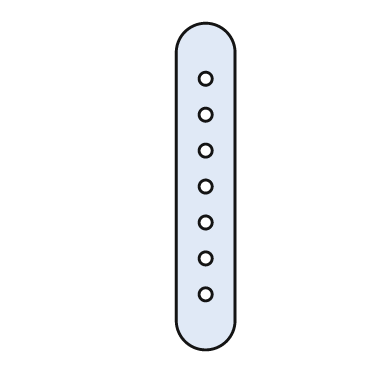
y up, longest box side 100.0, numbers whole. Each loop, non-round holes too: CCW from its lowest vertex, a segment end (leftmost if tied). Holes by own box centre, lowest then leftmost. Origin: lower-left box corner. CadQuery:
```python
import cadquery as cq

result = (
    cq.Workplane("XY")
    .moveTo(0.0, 9.0)
    .threePointArc((9.0, 0.0), (18.0, 9.0))
    .lineTo(18.0, 91.0)
    .threePointArc((9.0, 100.0), (0.0, 91.0))
    .close()
    .moveTo(9.0, 17.0)
    .circle(2.0)
    .moveTo(9.0, 28.0)
    .circle(2.0)
    .moveTo(9.0, 39.0)
    .circle(2.0)
    .moveTo(9.0, 50.0)
    .circle(2.0)
    .moveTo(9.0, 61.0)
    .circle(2.0)
    .moveTo(9.0, 72.0)
    .circle(2.0)
    .moveTo(9.0, 83.0)
    .circle(2.0)
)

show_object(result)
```